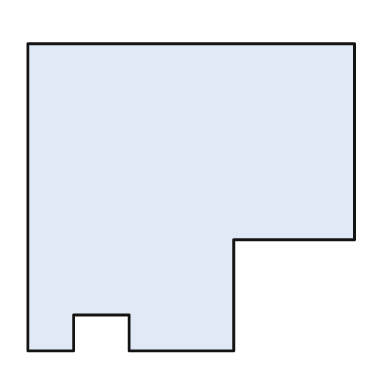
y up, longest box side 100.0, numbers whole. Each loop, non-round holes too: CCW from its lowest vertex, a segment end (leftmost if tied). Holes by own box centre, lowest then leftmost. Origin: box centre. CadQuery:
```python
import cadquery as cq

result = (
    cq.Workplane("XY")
    .moveTo(-50.0, -47.0)
    .lineTo(-36.0, -47.0)
    .lineTo(-36.0, -36.0)
    .lineTo(-19.0, -36.0)
    .lineTo(-19.0, -47.0)
    .lineTo(13.0, -47.0)
    .lineTo(13.0, -13.0)
    .lineTo(50.0, -13.0)
    .lineTo(50.0, 47.0)
    .lineTo(-50.0, 47.0)
    .close()
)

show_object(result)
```